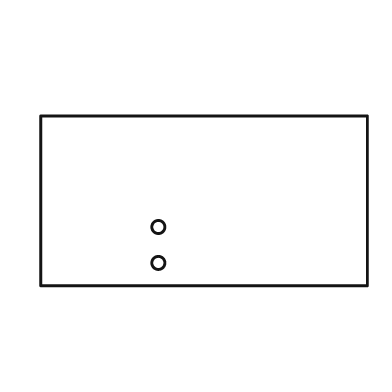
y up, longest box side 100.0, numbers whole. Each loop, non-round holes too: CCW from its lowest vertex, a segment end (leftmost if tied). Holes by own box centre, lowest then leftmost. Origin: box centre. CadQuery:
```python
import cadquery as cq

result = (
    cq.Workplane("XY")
    .moveTo(-50.0, -26.0)
    .lineTo(50.0, -26.0)
    .lineTo(50.0, 26.0)
    .lineTo(-50.0, 26.0)
    .close()
    .moveTo(-14.0, -19.0)
    .circle(2.0)
    .moveTo(-14.0, -8.0)
    .circle(2.0)
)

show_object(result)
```